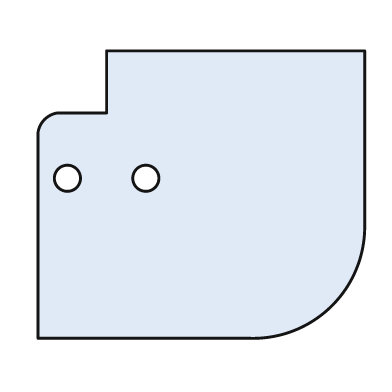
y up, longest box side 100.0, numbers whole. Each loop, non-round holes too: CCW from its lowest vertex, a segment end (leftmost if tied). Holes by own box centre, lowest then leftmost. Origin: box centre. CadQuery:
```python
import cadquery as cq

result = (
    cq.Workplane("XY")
    .moveTo(-50.0, -44.0)
    .lineTo(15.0, -44.0)
    .threePointArc((40.0, -34.0), (50.0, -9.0))
    .lineTo(50.0, 44.0)
    .lineTo(-29.0, 44.0)
    .lineTo(-29.0, 25.0)
    .lineTo(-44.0, 25.0)
    .threePointArc((-48.0, 23.0), (-50.0, 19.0))
    .close()
    .moveTo(-41.0, 5.0)
    .circle(4.0)
    .moveTo(-17.0, 5.0)
    .circle(4.0)
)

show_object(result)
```